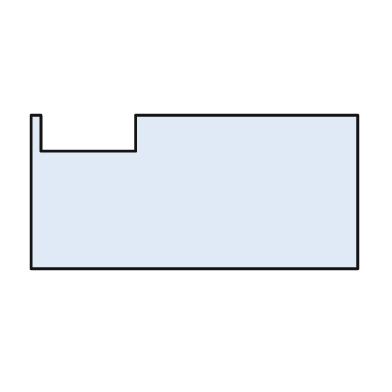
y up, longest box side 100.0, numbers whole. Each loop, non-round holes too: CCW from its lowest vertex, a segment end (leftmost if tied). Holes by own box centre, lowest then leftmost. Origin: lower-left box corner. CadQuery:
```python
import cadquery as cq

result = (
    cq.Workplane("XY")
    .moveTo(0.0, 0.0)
    .lineTo(100.0, 0.0)
    .lineTo(100.0, 47.0)
    .lineTo(32.0, 47.0)
    .lineTo(32.0, 36.0)
    .lineTo(3.0, 36.0)
    .lineTo(3.0, 47.0)
    .lineTo(0.0, 47.0)
    .close()
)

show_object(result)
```